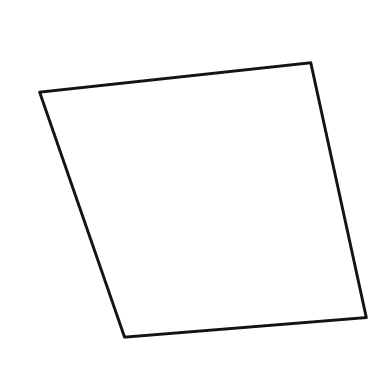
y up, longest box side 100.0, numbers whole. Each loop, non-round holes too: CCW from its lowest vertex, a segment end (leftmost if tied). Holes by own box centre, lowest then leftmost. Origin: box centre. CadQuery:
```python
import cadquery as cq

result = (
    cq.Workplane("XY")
    .moveTo(-24.0, -42.0)
    .lineTo(50.0, -36.0)
    .lineTo(33.0, 42.0)
    .lineTo(-50.0, 33.0)
    .close()
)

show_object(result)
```